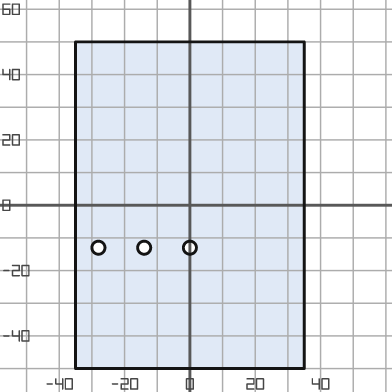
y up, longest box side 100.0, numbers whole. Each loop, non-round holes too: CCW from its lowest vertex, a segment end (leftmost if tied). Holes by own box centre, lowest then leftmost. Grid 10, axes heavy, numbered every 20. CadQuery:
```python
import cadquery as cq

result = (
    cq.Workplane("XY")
    .moveTo(-35.0, -50.0)
    .lineTo(35.0, -50.0)
    .lineTo(35.0, 50.0)
    .lineTo(-35.0, 50.0)
    .close()
    .moveTo(-28.0, -13.0)
    .circle(2.0)
    .moveTo(-14.0, -13.0)
    .circle(2.0)
    .moveTo(0.0, -13.0)
    .circle(2.0)
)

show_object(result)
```